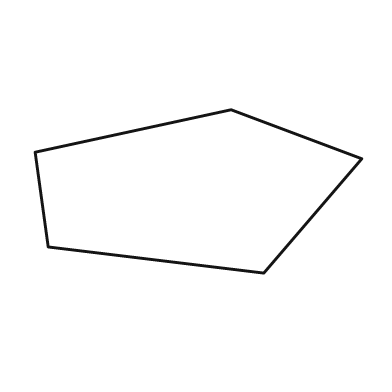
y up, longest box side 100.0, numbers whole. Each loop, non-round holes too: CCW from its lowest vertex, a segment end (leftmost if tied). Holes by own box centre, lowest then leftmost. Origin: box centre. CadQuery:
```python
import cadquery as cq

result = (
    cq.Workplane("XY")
    .moveTo(20.0, -25.0)
    .lineTo(50.0, 10.0)
    .lineTo(10.0, 25.0)
    .lineTo(-50.0, 12.0)
    .lineTo(-46.0, -17.0)
    .close()
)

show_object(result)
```